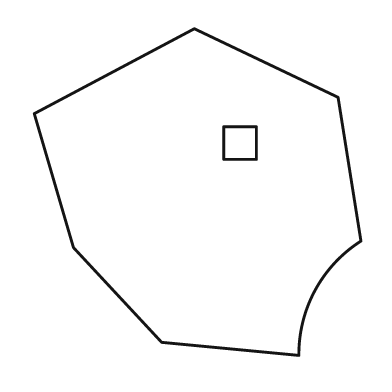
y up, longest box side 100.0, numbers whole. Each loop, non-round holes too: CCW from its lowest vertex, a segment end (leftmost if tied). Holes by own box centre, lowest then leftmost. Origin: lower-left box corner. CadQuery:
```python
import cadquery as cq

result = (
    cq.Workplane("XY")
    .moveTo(81.0, 0.0)
    .threePointArc((86.0, 20.0), (100.0, 35.0))
    .lineTo(93.0, 79.0)
    .lineTo(49.0, 100.0)
    .lineTo(0.0, 74.0)
    .lineTo(12.0, 33.0)
    .lineTo(39.0, 4.0)
    .close()
    .moveTo(58.0, 60.0)
    .lineTo(68.0, 60.0)
    .lineTo(68.0, 70.0)
    .lineTo(58.0, 70.0)
    .close()
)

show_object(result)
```